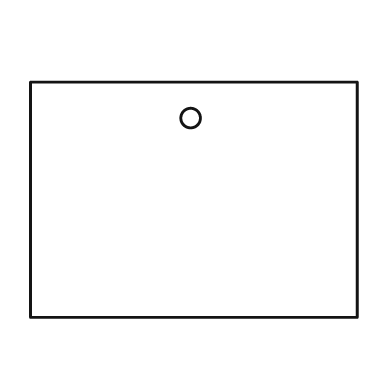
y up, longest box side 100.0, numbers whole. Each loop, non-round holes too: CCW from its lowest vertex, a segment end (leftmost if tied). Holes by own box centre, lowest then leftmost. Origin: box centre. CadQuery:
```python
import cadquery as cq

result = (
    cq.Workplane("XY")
    .moveTo(-50.0, -36.0)
    .lineTo(50.0, -36.0)
    .lineTo(50.0, 36.0)
    .lineTo(-50.0, 36.0)
    .close()
    .moveTo(-1.0, 25.0)
    .circle(3.0)
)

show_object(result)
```